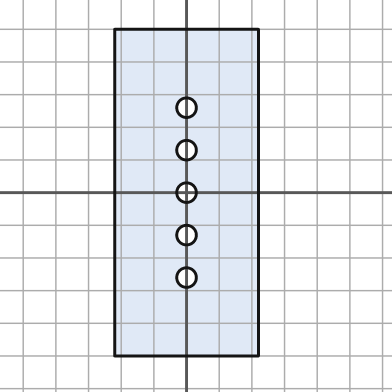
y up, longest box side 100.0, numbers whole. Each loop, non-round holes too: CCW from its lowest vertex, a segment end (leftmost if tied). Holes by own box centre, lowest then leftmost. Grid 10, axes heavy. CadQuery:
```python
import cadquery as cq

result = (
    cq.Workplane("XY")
    .moveTo(-22.0, -50.0)
    .lineTo(22.0, -50.0)
    .lineTo(22.0, 50.0)
    .lineTo(-22.0, 50.0)
    .close()
    .moveTo(0.0, -26.0)
    .circle(3.0)
    .moveTo(0.0, -13.0)
    .circle(3.0)
    .moveTo(0.0, 0.0)
    .circle(3.0)
    .moveTo(0.0, 13.0)
    .circle(3.0)
    .moveTo(0.0, 26.0)
    .circle(3.0)
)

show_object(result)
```